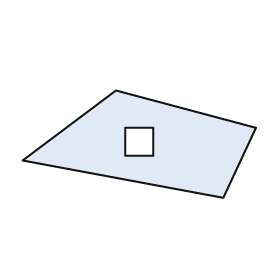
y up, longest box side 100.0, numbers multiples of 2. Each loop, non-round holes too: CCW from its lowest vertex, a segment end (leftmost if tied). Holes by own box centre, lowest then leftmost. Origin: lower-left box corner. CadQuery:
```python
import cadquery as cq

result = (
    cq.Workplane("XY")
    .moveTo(86.0, 0.0)
    .lineTo(100.0, 30.0)
    .lineTo(40.0, 46.0)
    .lineTo(0.0, 16.0)
    .close()
    .moveTo(44.0, 18.0)
    .lineTo(56.0, 18.0)
    .lineTo(56.0, 30.0)
    .lineTo(44.0, 30.0)
    .close()
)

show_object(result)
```